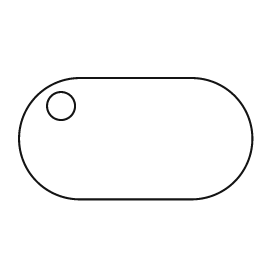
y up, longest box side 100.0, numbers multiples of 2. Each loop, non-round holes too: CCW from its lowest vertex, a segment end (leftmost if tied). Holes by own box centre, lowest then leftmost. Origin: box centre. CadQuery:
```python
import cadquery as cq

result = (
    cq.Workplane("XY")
    .moveTo(-24.0, -26.0)
    .lineTo(24.0, -26.0)
    .threePointArc((50.0, 0.0), (24.0, 26.0))
    .lineTo(-24.0, 26.0)
    .threePointArc((-50.0, 0.0), (-24.0, -26.0))
    .close()
    .moveTo(-32.0, 14.0)
    .circle(6.0)
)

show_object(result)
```